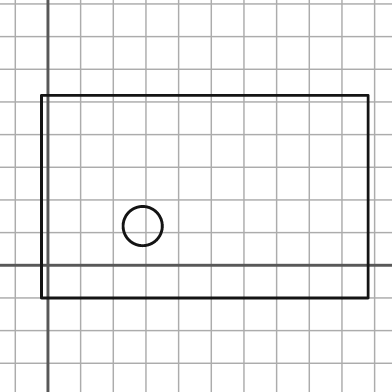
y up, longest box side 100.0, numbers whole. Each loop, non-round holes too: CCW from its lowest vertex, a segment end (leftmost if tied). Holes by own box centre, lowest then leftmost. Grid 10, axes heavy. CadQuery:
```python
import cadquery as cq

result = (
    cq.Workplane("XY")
    .moveTo(-2.0, -10.0)
    .lineTo(98.0, -10.0)
    .lineTo(98.0, 52.0)
    .lineTo(-2.0, 52.0)
    .close()
    .moveTo(29.0, 12.0)
    .circle(6.0)
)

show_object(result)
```